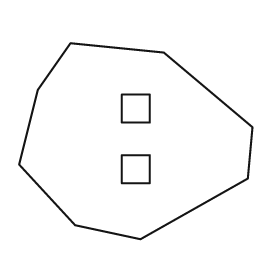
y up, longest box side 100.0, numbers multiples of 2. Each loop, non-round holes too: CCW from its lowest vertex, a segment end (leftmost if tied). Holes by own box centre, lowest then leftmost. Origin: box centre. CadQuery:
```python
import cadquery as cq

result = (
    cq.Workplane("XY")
    .moveTo(2.0, -42.0)
    .lineTo(48.0, -16.0)
    .lineTo(50.0, 6.0)
    .lineTo(12.0, 38.0)
    .lineTo(-28.0, 42.0)
    .lineTo(-42.0, 22.0)
    .lineTo(-50.0, -10.0)
    .lineTo(-26.0, -36.0)
    .close()
    .moveTo(-6.0, -18.0)
    .lineTo(6.0, -18.0)
    .lineTo(6.0, -6.0)
    .lineTo(-6.0, -6.0)
    .close()
    .moveTo(-6.0, 8.0)
    .lineTo(6.0, 8.0)
    .lineTo(6.0, 20.0)
    .lineTo(-6.0, 20.0)
    .close()
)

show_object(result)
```